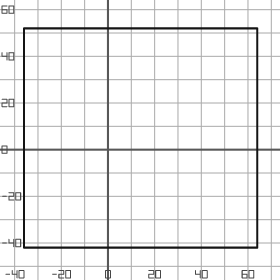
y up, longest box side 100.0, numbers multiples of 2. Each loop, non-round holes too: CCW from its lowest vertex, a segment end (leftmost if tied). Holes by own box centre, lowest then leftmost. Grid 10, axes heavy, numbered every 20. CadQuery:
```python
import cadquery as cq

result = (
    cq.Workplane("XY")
    .moveTo(-36.0, -42.0)
    .lineTo(64.0, -42.0)
    .lineTo(64.0, 52.0)
    .lineTo(-36.0, 52.0)
    .close()
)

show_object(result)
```